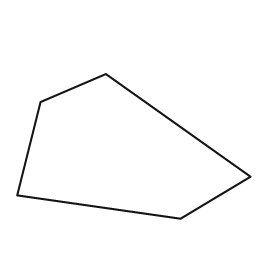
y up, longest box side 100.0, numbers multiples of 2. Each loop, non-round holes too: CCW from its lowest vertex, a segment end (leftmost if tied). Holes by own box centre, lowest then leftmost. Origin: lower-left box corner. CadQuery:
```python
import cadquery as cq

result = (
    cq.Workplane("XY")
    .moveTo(70.0, 0.0)
    .lineTo(100.0, 18.0)
    .lineTo(38.0, 62.0)
    .lineTo(10.0, 50.0)
    .lineTo(0.0, 10.0)
    .close()
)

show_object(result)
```